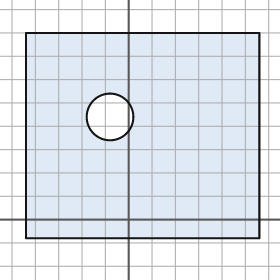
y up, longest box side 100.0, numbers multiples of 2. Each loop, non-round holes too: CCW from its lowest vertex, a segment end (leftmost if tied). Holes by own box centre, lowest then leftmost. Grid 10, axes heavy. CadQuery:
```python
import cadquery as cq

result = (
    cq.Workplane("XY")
    .moveTo(-44.0, -8.0)
    .lineTo(56.0, -8.0)
    .lineTo(56.0, 80.0)
    .lineTo(-44.0, 80.0)
    .close()
    .moveTo(-8.0, 44.0)
    .circle(10.0)
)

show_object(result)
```